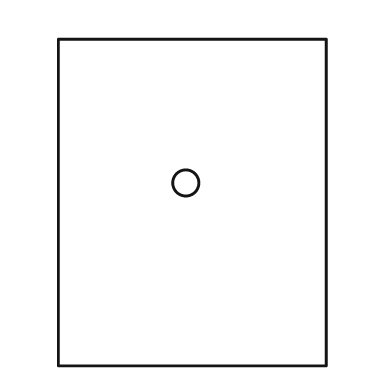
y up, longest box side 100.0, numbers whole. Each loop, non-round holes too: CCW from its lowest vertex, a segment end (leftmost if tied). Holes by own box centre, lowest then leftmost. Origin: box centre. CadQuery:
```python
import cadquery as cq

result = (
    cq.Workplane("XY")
    .moveTo(-41.0, -50.0)
    .lineTo(41.0, -50.0)
    .lineTo(41.0, 50.0)
    .lineTo(-41.0, 50.0)
    .close()
    .moveTo(-2.0, 6.0)
    .circle(4.0)
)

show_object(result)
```